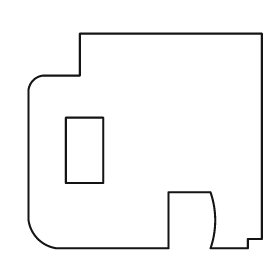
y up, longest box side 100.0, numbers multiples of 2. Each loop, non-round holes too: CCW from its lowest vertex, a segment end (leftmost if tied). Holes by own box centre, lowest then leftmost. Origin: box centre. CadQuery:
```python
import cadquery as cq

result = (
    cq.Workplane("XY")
    .moveTo(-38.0, -46.0)
    .lineTo(10.0, -46.0)
    .lineTo(10.0, -22.0)
    .lineTo(28.0, -22.0)
    .threePointArc((30.0, -34.0), (28.0, -46.0))
    .lineTo(44.0, -46.0)
    .lineTo(44.0, -42.0)
    .lineTo(50.0, -42.0)
    .lineTo(50.0, 46.0)
    .lineTo(-28.0, 46.0)
    .lineTo(-28.0, 28.0)
    .lineTo(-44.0, 28.0)
    .threePointArc((-48.0, 26.0), (-50.0, 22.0))
    .lineTo(-50.0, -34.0)
    .threePointArc((-46.0, -42.0), (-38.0, -46.0))
    .close()
    .moveTo(-34.0, -18.0)
    .lineTo(-18.0, -18.0)
    .lineTo(-18.0, 10.0)
    .lineTo(-34.0, 10.0)
    .close()
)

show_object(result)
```